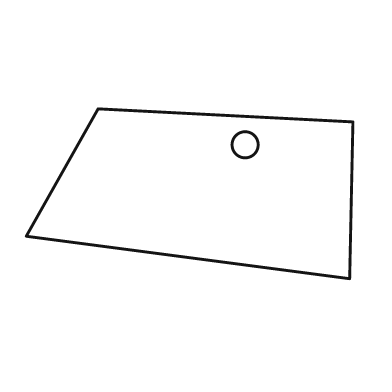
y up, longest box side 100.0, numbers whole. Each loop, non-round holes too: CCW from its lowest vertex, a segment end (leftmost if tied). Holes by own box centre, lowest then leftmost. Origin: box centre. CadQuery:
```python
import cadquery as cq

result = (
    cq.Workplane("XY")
    .moveTo(49.0, -26.0)
    .lineTo(50.0, 22.0)
    .lineTo(-28.0, 26.0)
    .lineTo(-50.0, -13.0)
    .close()
    .moveTo(17.0, 15.0)
    .circle(4.0)
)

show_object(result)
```